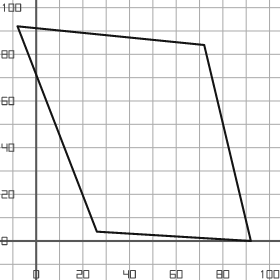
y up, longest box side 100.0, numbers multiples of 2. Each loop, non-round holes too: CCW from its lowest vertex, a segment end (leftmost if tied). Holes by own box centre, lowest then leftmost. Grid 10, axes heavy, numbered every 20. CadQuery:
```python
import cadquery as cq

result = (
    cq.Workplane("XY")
    .moveTo(92.0, 0.0)
    .lineTo(72.0, 84.0)
    .lineTo(-8.0, 92.0)
    .lineTo(26.0, 4.0)
    .close()
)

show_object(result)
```